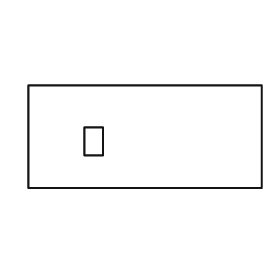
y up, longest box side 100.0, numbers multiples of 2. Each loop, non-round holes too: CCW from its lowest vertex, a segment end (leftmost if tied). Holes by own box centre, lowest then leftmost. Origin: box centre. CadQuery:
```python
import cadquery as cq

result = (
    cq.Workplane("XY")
    .moveTo(-50.0, -22.0)
    .lineTo(50.0, -22.0)
    .lineTo(50.0, 22.0)
    .lineTo(-50.0, 22.0)
    .close()
    .moveTo(-26.0, -8.0)
    .lineTo(-18.0, -8.0)
    .lineTo(-18.0, 4.0)
    .lineTo(-26.0, 4.0)
    .close()
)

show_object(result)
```